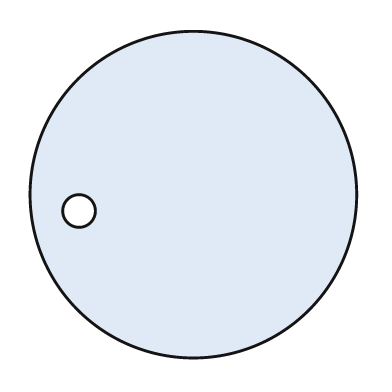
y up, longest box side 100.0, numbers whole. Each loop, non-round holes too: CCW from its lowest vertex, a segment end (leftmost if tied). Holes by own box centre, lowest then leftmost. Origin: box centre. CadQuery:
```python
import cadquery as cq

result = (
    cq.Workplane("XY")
    .moveTo(0.0, 0.0)
    .circle(50.0)
    .moveTo(-35.0, -5.0)
    .circle(5.0)
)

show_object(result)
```